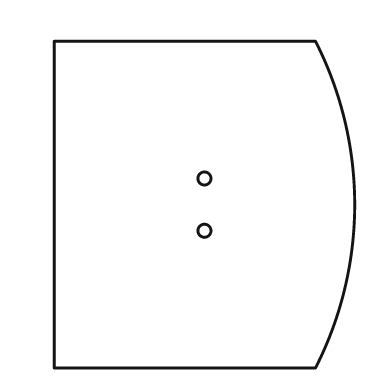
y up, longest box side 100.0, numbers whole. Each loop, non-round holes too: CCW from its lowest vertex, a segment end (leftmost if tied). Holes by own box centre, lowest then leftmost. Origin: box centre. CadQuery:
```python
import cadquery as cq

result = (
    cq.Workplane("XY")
    .moveTo(-46.0, -50.0)
    .lineTo(34.0, -50.0)
    .threePointArc((46.0, 0.0), (34.0, 50.0))
    .lineTo(-46.0, 50.0)
    .close()
    .moveTo(0.0, -8.0)
    .circle(2.0)
    .moveTo(0.0, 8.0)
    .circle(2.0)
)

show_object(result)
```